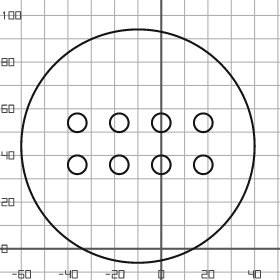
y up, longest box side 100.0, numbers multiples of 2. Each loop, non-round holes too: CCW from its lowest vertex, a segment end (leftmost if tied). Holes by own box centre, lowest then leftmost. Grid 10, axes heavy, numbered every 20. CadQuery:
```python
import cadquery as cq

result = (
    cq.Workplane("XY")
    .moveTo(-10.0, 44.0)
    .circle(50.0)
    .moveTo(-36.0, 36.0)
    .circle(4.0)
    .moveTo(-18.0, 36.0)
    .circle(4.0)
    .moveTo(0.0, 36.0)
    .circle(4.0)
    .moveTo(18.0, 36.0)
    .circle(4.0)
    .moveTo(-36.0, 54.0)
    .circle(4.0)
    .moveTo(-18.0, 54.0)
    .circle(4.0)
    .moveTo(0.0, 54.0)
    .circle(4.0)
    .moveTo(18.0, 54.0)
    .circle(4.0)
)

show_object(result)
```